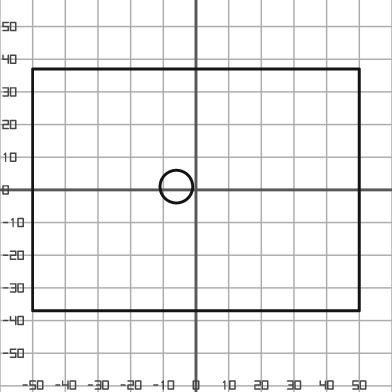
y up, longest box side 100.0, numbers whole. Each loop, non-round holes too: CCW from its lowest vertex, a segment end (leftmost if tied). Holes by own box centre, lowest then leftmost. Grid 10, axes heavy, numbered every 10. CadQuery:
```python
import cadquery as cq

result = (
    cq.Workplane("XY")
    .moveTo(-50.0, -37.0)
    .lineTo(50.0, -37.0)
    .lineTo(50.0, 37.0)
    .lineTo(-50.0, 37.0)
    .close()
    .moveTo(-6.0, 1.0)
    .circle(5.0)
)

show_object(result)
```